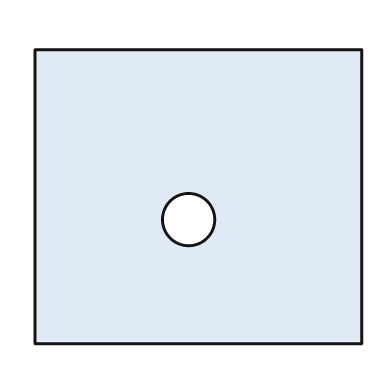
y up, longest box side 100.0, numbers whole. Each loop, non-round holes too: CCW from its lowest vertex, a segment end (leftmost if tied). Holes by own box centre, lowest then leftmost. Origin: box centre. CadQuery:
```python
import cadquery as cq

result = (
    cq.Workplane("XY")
    .moveTo(-50.0, -45.0)
    .lineTo(50.0, -45.0)
    .lineTo(50.0, 45.0)
    .lineTo(-50.0, 45.0)
    .close()
    .moveTo(-3.0, -7.0)
    .circle(8.0)
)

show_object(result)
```